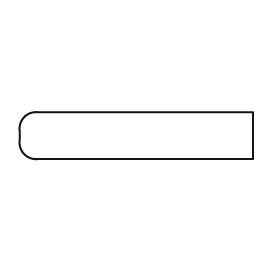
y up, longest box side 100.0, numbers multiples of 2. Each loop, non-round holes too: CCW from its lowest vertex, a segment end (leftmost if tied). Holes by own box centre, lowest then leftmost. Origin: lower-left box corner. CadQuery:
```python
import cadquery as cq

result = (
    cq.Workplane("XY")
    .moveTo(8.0, 0.0)
    .lineTo(100.0, 0.0)
    .lineTo(100.0, 20.0)
    .lineTo(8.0, 20.0)
    .threePointArc((2.0, 18.0), (0.0, 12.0))
    .lineTo(0.0, 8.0)
    .threePointArc((2.0, 2.0), (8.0, 0.0))
    .close()
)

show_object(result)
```